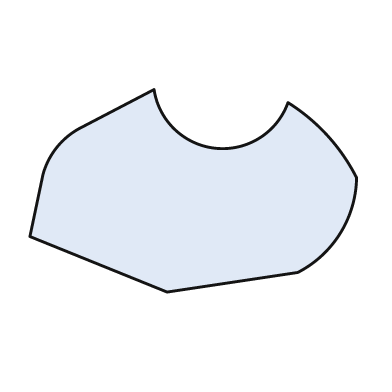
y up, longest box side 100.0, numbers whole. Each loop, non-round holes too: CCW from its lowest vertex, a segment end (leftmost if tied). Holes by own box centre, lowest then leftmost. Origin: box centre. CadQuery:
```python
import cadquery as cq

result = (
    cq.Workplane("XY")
    .moveTo(-8.0, -31.0)
    .lineTo(32.0, -25.0)
    .threePointArc((45.0, -13.0), (50.0, 4.0))
    .threePointArc((41.0, 17.0), (29.0, 27.0))
    .threePointArc((7.0, 13.0), (-12.0, 31.0))
    .lineTo(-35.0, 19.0)
    .threePointArc((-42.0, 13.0), (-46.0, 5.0))
    .lineTo(-50.0, -14.0)
    .close()
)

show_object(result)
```